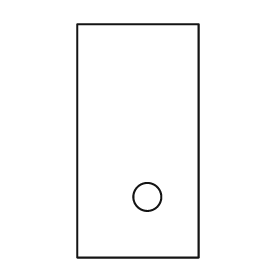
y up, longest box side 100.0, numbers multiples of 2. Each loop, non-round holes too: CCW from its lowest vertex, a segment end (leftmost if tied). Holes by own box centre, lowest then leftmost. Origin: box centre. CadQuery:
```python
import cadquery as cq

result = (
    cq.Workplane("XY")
    .moveTo(-26.0, -50.0)
    .lineTo(26.0, -50.0)
    .lineTo(26.0, 50.0)
    .lineTo(-26.0, 50.0)
    .close()
    .moveTo(4.0, -24.0)
    .circle(6.0)
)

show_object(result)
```